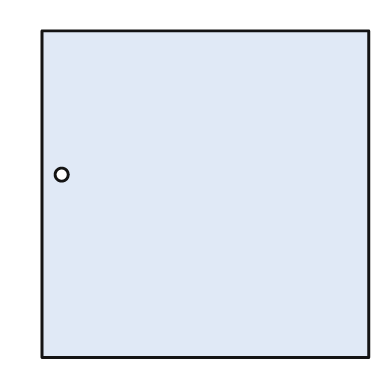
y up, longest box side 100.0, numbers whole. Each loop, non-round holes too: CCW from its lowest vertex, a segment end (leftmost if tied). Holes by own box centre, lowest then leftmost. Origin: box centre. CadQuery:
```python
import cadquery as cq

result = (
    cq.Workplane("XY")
    .moveTo(-50.0, -50.0)
    .lineTo(50.0, -50.0)
    .lineTo(50.0, 50.0)
    .lineTo(-50.0, 50.0)
    .close()
    .moveTo(-44.0, 6.0)
    .circle(2.0)
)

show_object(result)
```